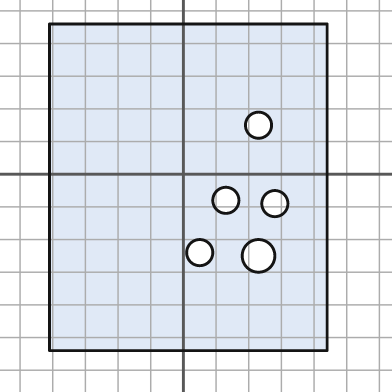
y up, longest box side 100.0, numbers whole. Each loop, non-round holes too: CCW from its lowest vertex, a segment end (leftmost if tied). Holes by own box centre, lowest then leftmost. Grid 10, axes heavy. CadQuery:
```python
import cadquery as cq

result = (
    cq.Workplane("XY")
    .moveTo(-41.0, -54.0)
    .lineTo(44.0, -54.0)
    .lineTo(44.0, 46.0)
    .lineTo(-41.0, 46.0)
    .close()
    .moveTo(23.0, -25.0)
    .circle(5.0)
    .moveTo(5.0, -24.0)
    .circle(4.0)
    .moveTo(28.0, -9.0)
    .circle(4.0)
    .moveTo(13.0, -8.0)
    .circle(4.0)
    .moveTo(23.0, 15.0)
    .circle(4.0)
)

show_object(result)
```